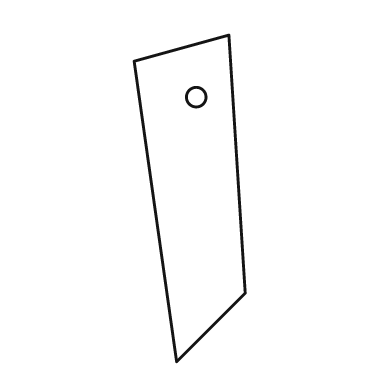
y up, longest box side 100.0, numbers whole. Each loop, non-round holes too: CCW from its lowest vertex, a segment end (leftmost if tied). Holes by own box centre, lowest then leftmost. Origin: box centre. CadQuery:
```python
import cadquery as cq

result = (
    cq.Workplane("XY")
    .moveTo(-4.0, -50.0)
    .lineTo(17.0, -29.0)
    .lineTo(12.0, 50.0)
    .lineTo(-17.0, 42.0)
    .close()
    .moveTo(2.0, 31.0)
    .circle(3.0)
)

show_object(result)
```